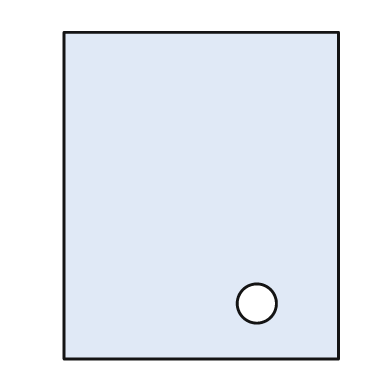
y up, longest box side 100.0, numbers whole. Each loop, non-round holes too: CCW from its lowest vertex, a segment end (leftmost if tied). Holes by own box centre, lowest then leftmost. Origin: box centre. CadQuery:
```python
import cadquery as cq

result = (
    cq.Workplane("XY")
    .moveTo(-42.0, -50.0)
    .lineTo(42.0, -50.0)
    .lineTo(42.0, 50.0)
    .lineTo(-42.0, 50.0)
    .close()
    .moveTo(17.0, -33.0)
    .circle(6.0)
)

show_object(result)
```